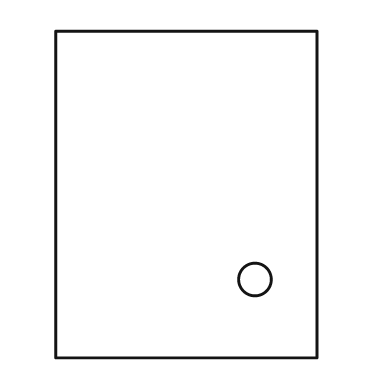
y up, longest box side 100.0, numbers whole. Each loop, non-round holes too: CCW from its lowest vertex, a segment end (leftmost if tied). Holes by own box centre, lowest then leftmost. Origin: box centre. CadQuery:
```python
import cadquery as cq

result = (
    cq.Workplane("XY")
    .moveTo(-40.0, -50.0)
    .lineTo(40.0, -50.0)
    .lineTo(40.0, 50.0)
    .lineTo(-40.0, 50.0)
    .close()
    .moveTo(21.0, -26.0)
    .circle(5.0)
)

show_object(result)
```